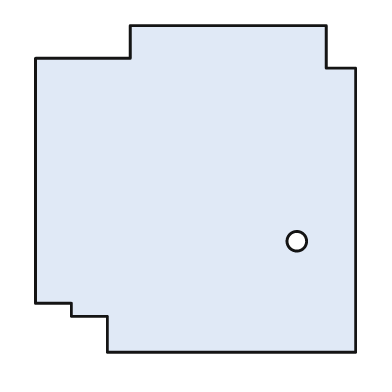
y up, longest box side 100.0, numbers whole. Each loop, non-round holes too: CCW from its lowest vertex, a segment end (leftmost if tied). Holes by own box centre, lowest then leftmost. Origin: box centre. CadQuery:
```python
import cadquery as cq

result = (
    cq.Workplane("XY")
    .moveTo(-27.0, -50.0)
    .lineTo(49.0, -50.0)
    .lineTo(49.0, 37.0)
    .lineTo(40.0, 37.0)
    .lineTo(40.0, 50.0)
    .lineTo(-20.0, 50.0)
    .lineTo(-20.0, 40.0)
    .lineTo(-49.0, 40.0)
    .lineTo(-49.0, -35.0)
    .lineTo(-38.0, -35.0)
    .lineTo(-38.0, -39.0)
    .lineTo(-27.0, -39.0)
    .close()
    .moveTo(31.0, -16.0)
    .circle(3.0)
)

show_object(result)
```